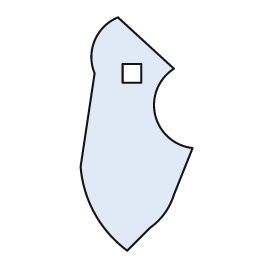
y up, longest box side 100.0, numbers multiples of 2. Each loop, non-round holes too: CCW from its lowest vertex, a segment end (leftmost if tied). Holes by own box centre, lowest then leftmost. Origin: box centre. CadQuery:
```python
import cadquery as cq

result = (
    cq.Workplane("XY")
    .moveTo(-4.0, -50.0)
    .lineTo(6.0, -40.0)
    .threePointArc((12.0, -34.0), (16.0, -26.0))
    .lineTo(24.0, -6.0)
    .threePointArc((8.0, 8.0), (16.0, 28.0))
    .lineTo(-8.0, 50.0)
    .threePointArc((-18.0, 40.0), (-18.0, 26.0))
    .lineTo(-24.0, -14.0)
    .threePointArc((-18.0, -34.0), (-4.0, -50.0))
    .close()
    .moveTo(-6.0, 22.0)
    .lineTo(2.0, 22.0)
    .lineTo(2.0, 30.0)
    .lineTo(-6.0, 30.0)
    .close()
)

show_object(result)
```